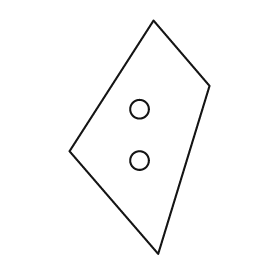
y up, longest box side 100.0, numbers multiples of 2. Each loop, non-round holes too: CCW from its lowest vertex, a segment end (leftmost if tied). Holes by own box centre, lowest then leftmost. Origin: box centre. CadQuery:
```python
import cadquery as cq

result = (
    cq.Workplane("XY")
    .moveTo(8.0, -50.0)
    .lineTo(30.0, 22.0)
    .lineTo(6.0, 50.0)
    .lineTo(-30.0, -6.0)
    .close()
    .moveTo(0.0, -10.0)
    .circle(4.0)
    .moveTo(0.0, 12.0)
    .circle(4.0)
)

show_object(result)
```